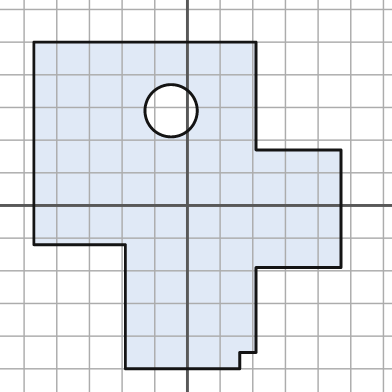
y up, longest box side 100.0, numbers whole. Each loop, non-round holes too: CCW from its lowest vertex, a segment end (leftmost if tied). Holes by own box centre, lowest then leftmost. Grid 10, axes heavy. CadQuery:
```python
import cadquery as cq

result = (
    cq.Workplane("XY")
    .moveTo(-19.0, -50.0)
    .lineTo(16.0, -50.0)
    .lineTo(16.0, -45.0)
    .lineTo(21.0, -45.0)
    .lineTo(21.0, -19.0)
    .lineTo(47.0, -19.0)
    .lineTo(47.0, 17.0)
    .lineTo(21.0, 17.0)
    .lineTo(21.0, 50.0)
    .lineTo(-47.0, 50.0)
    .lineTo(-47.0, -12.0)
    .lineTo(-19.0, -12.0)
    .close()
    .moveTo(-5.0, 29.0)
    .circle(8.0)
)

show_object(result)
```